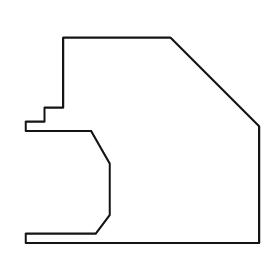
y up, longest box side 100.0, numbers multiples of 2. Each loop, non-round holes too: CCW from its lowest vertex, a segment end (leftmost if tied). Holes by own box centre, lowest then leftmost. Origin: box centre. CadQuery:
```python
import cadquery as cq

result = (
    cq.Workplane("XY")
    .moveTo(-50.0, -44.0)
    .lineTo(50.0, -44.0)
    .lineTo(50.0, 6.0)
    .lineTo(12.0, 44.0)
    .lineTo(-34.0, 44.0)
    .lineTo(-34.0, 14.0)
    .lineTo(-42.0, 14.0)
    .lineTo(-42.0, 8.0)
    .lineTo(-50.0, 8.0)
    .lineTo(-50.0, 4.0)
    .lineTo(-22.0, 4.0)
    .lineTo(-14.0, -10.0)
    .lineTo(-14.0, -32.0)
    .lineTo(-20.0, -40.0)
    .lineTo(-50.0, -40.0)
    .close()
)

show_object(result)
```